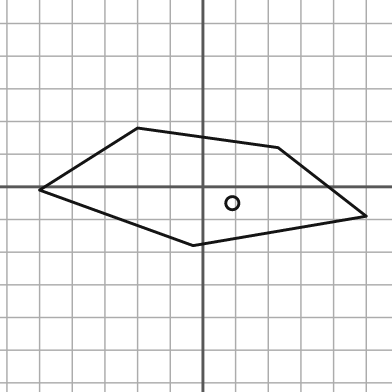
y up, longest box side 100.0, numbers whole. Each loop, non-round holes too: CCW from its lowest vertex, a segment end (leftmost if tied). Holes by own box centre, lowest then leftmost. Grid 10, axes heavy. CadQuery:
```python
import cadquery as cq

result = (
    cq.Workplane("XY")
    .moveTo(-3.0, -18.0)
    .lineTo(50.0, -9.0)
    .lineTo(23.0, 12.0)
    .lineTo(-20.0, 18.0)
    .lineTo(-50.0, -1.0)
    .close()
    .moveTo(9.0, -5.0)
    .circle(2.0)
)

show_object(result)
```